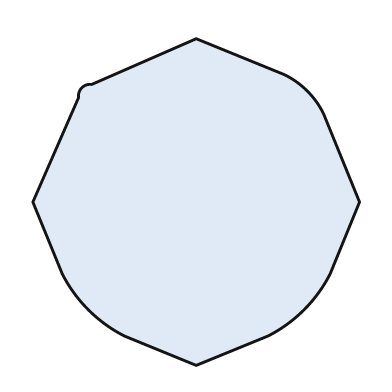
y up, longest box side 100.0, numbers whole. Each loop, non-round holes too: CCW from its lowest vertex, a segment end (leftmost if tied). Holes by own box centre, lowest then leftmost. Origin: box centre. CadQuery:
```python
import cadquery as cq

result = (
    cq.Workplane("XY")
    .moveTo(0.0, -50.0)
    .lineTo(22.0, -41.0)
    .threePointArc((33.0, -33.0), (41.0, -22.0))
    .lineTo(50.0, 0.0)
    .lineTo(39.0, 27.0)
    .threePointArc((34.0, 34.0), (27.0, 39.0))
    .lineTo(0.0, 50.0)
    .lineTo(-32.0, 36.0)
    .threePointArc((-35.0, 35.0), (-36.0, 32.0))
    .lineTo(-50.0, 0.0)
    .lineTo(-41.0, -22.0)
    .threePointArc((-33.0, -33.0), (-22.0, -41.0))
    .close()
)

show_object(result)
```